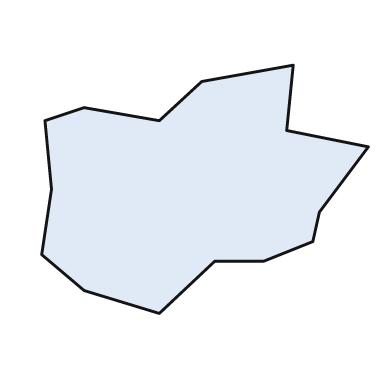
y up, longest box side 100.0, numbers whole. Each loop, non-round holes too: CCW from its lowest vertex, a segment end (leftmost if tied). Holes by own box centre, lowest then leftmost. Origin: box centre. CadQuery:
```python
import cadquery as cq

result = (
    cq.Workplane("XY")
    .moveTo(-14.0, -38.0)
    .lineTo(3.0, -22.0)
    .lineTo(18.0, -22.0)
    .lineTo(33.0, -16.0)
    .lineTo(35.0, -7.0)
    .lineTo(50.0, 13.0)
    .lineTo(25.0, 18.0)
    .lineTo(27.0, 38.0)
    .lineTo(-1.0, 33.0)
    .lineTo(-14.0, 21.0)
    .lineTo(-37.0, 25.0)
    .lineTo(-49.0, 21.0)
    .lineTo(-47.0, 0.0)
    .lineTo(-50.0, -20.0)
    .lineTo(-37.0, -31.0)
    .close()
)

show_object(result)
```